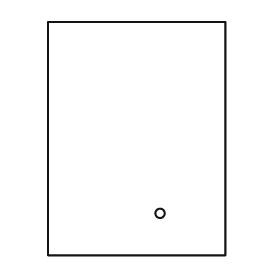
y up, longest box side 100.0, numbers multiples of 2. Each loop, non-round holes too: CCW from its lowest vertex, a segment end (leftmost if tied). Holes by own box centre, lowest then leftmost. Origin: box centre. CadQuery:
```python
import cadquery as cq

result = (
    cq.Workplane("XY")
    .moveTo(-38.0, -50.0)
    .lineTo(38.0, -50.0)
    .lineTo(38.0, 50.0)
    .lineTo(-38.0, 50.0)
    .close()
    .moveTo(10.0, -32.0)
    .circle(2.0)
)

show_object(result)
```